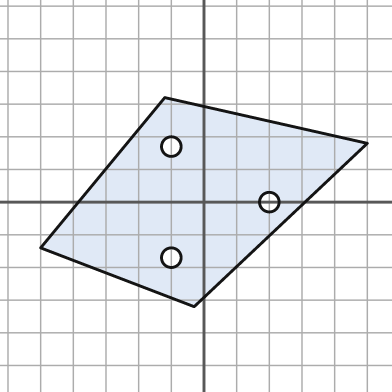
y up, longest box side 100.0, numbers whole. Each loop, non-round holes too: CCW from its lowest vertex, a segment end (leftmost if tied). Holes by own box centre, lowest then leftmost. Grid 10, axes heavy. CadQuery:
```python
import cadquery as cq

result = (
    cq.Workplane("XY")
    .moveTo(-3.0, -32.0)
    .lineTo(50.0, 18.0)
    .lineTo(-12.0, 32.0)
    .lineTo(-50.0, -14.0)
    .close()
    .moveTo(-10.0, -17.0)
    .circle(3.0)
    .moveTo(20.0, 0.0)
    .circle(3.0)
    .moveTo(-10.0, 17.0)
    .circle(3.0)
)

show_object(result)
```